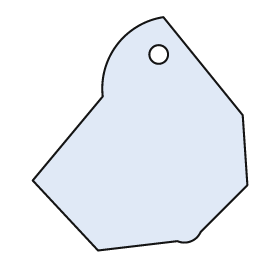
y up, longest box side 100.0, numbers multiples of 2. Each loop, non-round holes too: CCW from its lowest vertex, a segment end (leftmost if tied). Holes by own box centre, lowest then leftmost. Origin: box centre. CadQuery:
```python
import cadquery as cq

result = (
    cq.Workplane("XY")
    .moveTo(-18.0, -50.0)
    .lineTo(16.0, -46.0)
    .threePointArc((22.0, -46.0), (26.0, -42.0))
    .lineTo(46.0, -22.0)
    .lineTo(44.0, 8.0)
    .lineTo(10.0, 50.0)
    .threePointArc((-10.0, 38.0), (-16.0, 16.0))
    .lineTo(-46.0, -20.0)
    .close()
    .moveTo(8.0, 34.0)
    .circle(4.0)
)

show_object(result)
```